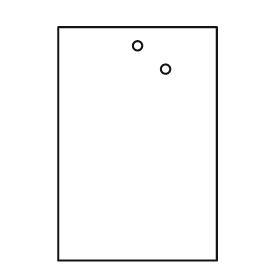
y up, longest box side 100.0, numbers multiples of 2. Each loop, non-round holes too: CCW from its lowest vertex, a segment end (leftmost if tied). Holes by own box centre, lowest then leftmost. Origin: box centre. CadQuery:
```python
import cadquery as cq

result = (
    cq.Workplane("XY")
    .moveTo(-34.0, -50.0)
    .lineTo(34.0, -50.0)
    .lineTo(34.0, 50.0)
    .lineTo(-34.0, 50.0)
    .close()
    .moveTo(12.0, 32.0)
    .circle(2.0)
    .moveTo(0.0, 42.0)
    .circle(2.0)
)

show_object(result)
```